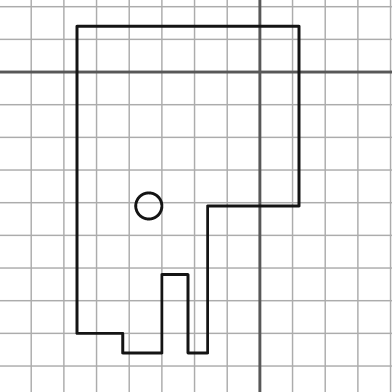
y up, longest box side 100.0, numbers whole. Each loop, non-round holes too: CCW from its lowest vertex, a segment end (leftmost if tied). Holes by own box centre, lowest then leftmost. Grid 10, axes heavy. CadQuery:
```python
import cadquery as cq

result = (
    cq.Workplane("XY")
    .moveTo(-42.0, -86.0)
    .lineTo(-30.0, -86.0)
    .lineTo(-30.0, -62.0)
    .lineTo(-22.0, -62.0)
    .lineTo(-22.0, -86.0)
    .lineTo(-16.0, -86.0)
    .lineTo(-16.0, -41.0)
    .lineTo(12.0, -41.0)
    .lineTo(12.0, 14.0)
    .lineTo(-56.0, 14.0)
    .lineTo(-56.0, -80.0)
    .lineTo(-42.0, -80.0)
    .close()
    .moveTo(-34.0, -41.0)
    .circle(4.0)
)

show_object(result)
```